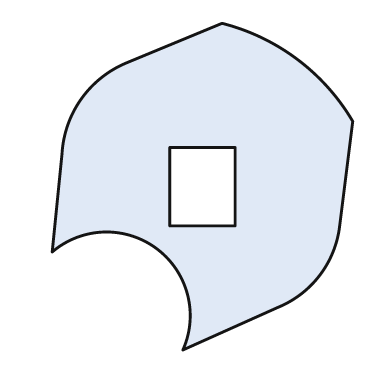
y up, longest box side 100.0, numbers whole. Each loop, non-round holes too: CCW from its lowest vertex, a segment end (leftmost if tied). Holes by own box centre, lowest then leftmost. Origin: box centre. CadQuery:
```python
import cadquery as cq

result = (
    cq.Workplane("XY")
    .moveTo(-6.0, -50.0)
    .lineTo(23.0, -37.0)
    .threePointArc((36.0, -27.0), (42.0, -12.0))
    .lineTo(46.0, 20.0)
    .threePointArc((29.0, 39.0), (6.0, 50.0))
    .lineTo(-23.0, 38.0)
    .threePointArc((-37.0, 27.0), (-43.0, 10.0))
    .lineTo(-46.0, -20.0)
    .threePointArc((-14.0, -19.0), (-6.0, -50.0))
    .close()
    .moveTo(-10.0, -12.0)
    .lineTo(10.0, -12.0)
    .lineTo(10.0, 12.0)
    .lineTo(-10.0, 12.0)
    .close()
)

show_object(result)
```